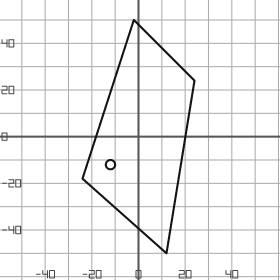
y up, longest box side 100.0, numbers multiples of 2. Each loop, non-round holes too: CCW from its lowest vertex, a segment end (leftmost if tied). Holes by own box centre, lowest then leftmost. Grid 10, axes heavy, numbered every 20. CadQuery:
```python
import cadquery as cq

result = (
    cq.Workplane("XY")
    .moveTo(12.0, -50.0)
    .lineTo(24.0, 24.0)
    .lineTo(-2.0, 50.0)
    .lineTo(-24.0, -18.0)
    .close()
    .moveTo(-12.0, -12.0)
    .circle(2.0)
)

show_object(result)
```